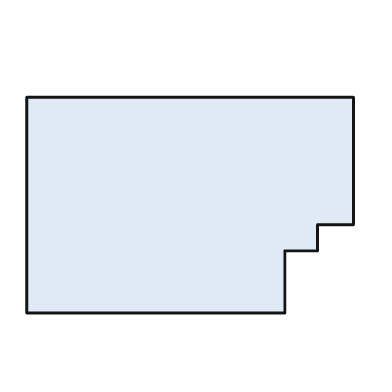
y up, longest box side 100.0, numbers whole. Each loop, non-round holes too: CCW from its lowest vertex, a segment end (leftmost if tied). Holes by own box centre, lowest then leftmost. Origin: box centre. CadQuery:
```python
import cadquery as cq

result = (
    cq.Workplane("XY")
    .moveTo(-50.0, -33.0)
    .lineTo(29.0, -33.0)
    .lineTo(29.0, -14.0)
    .lineTo(39.0, -14.0)
    .lineTo(39.0, -6.0)
    .lineTo(50.0, -6.0)
    .lineTo(50.0, 33.0)
    .lineTo(-50.0, 33.0)
    .close()
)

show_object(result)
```